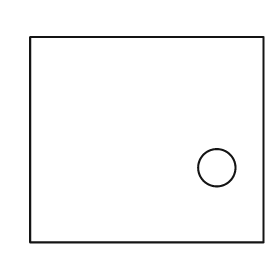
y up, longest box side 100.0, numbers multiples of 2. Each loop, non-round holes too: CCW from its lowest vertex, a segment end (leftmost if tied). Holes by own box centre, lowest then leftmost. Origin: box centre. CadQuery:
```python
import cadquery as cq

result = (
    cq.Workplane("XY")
    .moveTo(-50.0, -44.0)
    .lineTo(50.0, -44.0)
    .lineTo(50.0, 44.0)
    .lineTo(-50.0, 44.0)
    .close()
    .moveTo(30.0, -12.0)
    .circle(8.0)
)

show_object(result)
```